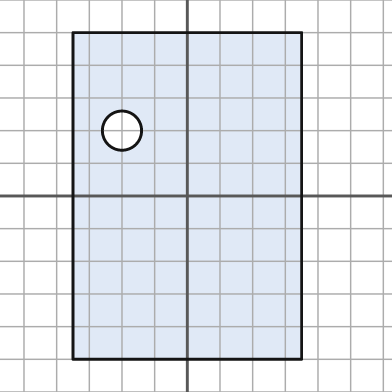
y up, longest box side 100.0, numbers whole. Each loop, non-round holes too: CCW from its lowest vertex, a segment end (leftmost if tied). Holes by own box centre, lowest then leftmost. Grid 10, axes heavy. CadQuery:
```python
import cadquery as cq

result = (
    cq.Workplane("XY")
    .moveTo(-35.0, -50.0)
    .lineTo(35.0, -50.0)
    .lineTo(35.0, 50.0)
    .lineTo(-35.0, 50.0)
    .close()
    .moveTo(-20.0, 20.0)
    .circle(6.0)
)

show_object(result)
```